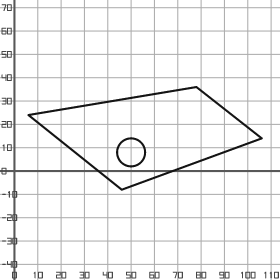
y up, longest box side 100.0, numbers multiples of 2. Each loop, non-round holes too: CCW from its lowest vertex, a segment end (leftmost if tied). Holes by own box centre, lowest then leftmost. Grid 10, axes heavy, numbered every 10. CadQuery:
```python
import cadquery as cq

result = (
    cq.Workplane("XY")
    .moveTo(46.0, -8.0)
    .lineTo(106.0, 14.0)
    .lineTo(78.0, 36.0)
    .lineTo(6.0, 24.0)
    .close()
    .moveTo(50.0, 8.0)
    .circle(6.0)
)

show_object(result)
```